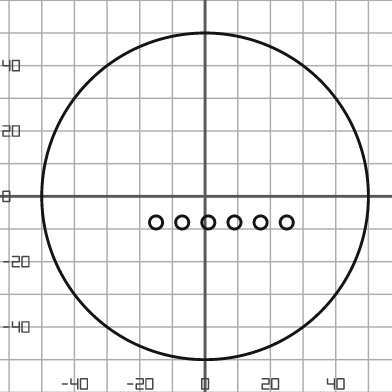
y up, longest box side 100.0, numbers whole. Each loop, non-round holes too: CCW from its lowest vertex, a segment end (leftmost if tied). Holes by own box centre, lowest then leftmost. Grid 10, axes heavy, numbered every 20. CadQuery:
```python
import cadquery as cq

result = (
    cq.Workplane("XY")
    .moveTo(0.0, 0.0)
    .circle(50.0)
    .moveTo(-15.0, -8.0)
    .circle(2.0)
    .moveTo(-7.0, -8.0)
    .circle(2.0)
    .moveTo(1.0, -8.0)
    .circle(2.0)
    .moveTo(9.0, -8.0)
    .circle(2.0)
    .moveTo(17.0, -8.0)
    .circle(2.0)
    .moveTo(25.0, -8.0)
    .circle(2.0)
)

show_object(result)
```